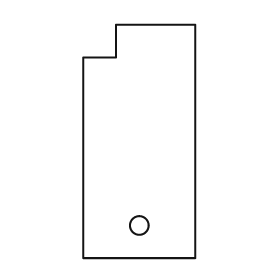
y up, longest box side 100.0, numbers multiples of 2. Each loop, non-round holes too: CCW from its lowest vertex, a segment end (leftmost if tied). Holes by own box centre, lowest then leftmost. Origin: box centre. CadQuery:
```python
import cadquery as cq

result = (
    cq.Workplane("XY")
    .moveTo(-24.0, -50.0)
    .lineTo(24.0, -50.0)
    .lineTo(24.0, 50.0)
    .lineTo(-10.0, 50.0)
    .lineTo(-10.0, 36.0)
    .lineTo(-24.0, 36.0)
    .close()
    .moveTo(0.0, -36.0)
    .circle(4.0)
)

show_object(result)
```